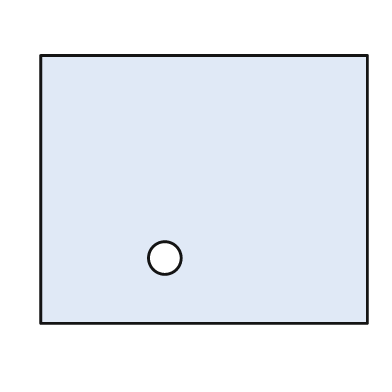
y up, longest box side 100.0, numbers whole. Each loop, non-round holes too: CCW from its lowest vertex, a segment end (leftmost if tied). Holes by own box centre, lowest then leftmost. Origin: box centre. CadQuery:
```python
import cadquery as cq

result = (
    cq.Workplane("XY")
    .moveTo(-50.0, -41.0)
    .lineTo(50.0, -41.0)
    .lineTo(50.0, 41.0)
    .lineTo(-50.0, 41.0)
    .close()
    .moveTo(-12.0, -21.0)
    .circle(5.0)
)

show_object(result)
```